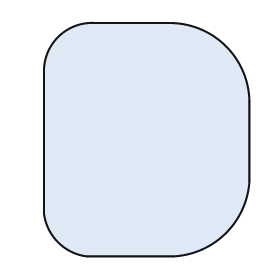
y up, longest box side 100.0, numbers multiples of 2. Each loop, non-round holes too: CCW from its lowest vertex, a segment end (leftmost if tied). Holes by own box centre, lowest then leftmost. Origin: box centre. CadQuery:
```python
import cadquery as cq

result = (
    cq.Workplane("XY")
    .moveTo(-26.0, -50.0)
    .lineTo(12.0, -50.0)
    .threePointArc((34.0, -40.0), (44.0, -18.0))
    .lineTo(44.0, 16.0)
    .threePointArc((34.0, 40.0), (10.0, 50.0))
    .lineTo(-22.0, 50.0)
    .threePointArc((-38.0, 44.0), (-44.0, 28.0))
    .lineTo(-44.0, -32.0)
    .threePointArc((-38.0, -44.0), (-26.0, -50.0))
    .close()
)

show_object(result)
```